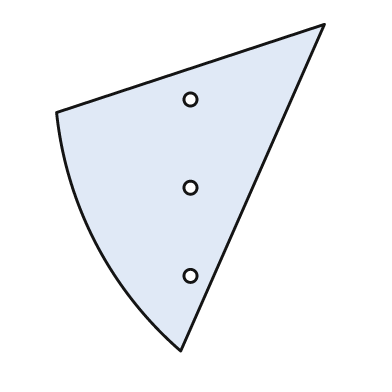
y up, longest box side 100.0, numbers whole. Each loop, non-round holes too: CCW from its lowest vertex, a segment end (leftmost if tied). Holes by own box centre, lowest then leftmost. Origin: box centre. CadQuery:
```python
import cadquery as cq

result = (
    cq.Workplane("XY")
    .moveTo(-3.0, -50.0)
    .lineTo(41.0, 50.0)
    .lineTo(-41.0, 23.0)
    .threePointArc((-29.0, -17.0), (-3.0, -50.0))
    .close()
    .moveTo(0.0, -27.0)
    .circle(2.0)
    .moveTo(0.0, 0.0)
    .circle(2.0)
    .moveTo(0.0, 27.0)
    .circle(2.0)
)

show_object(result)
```